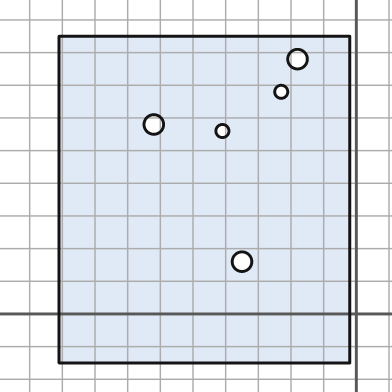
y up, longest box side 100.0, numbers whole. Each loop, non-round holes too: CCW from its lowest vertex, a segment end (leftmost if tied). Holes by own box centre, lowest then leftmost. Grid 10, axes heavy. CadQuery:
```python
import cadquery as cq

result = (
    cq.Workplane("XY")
    .moveTo(-91.0, -15.0)
    .lineTo(-2.0, -15.0)
    .lineTo(-2.0, 85.0)
    .lineTo(-91.0, 85.0)
    .close()
    .moveTo(-35.0, 16.0)
    .circle(3.0)
    .moveTo(-41.0, 56.0)
    .circle(2.0)
    .moveTo(-62.0, 58.0)
    .circle(3.0)
    .moveTo(-23.0, 68.0)
    .circle(2.0)
    .moveTo(-18.0, 78.0)
    .circle(3.0)
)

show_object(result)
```